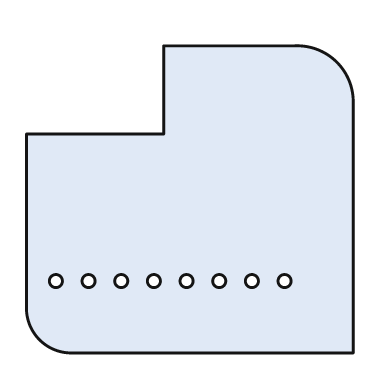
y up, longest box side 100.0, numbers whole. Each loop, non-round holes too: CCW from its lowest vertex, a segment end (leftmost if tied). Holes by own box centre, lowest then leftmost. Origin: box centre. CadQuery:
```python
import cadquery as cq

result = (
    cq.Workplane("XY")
    .moveTo(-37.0, -47.0)
    .lineTo(50.0, -47.0)
    .lineTo(50.0, 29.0)
    .threePointArc((45.0, 42.0), (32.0, 47.0))
    .lineTo(-8.0, 47.0)
    .lineTo(-8.0, 20.0)
    .lineTo(-50.0, 20.0)
    .lineTo(-50.0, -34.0)
    .threePointArc((-46.0, -43.0), (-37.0, -47.0))
    .close()
    .moveTo(-41.0, -25.0)
    .circle(2.0)
    .moveTo(-31.0, -25.0)
    .circle(2.0)
    .moveTo(-21.0, -25.0)
    .circle(2.0)
    .moveTo(-11.0, -25.0)
    .circle(2.0)
    .moveTo(-1.0, -25.0)
    .circle(2.0)
    .moveTo(9.0, -25.0)
    .circle(2.0)
    .moveTo(19.0, -25.0)
    .circle(2.0)
    .moveTo(29.0, -25.0)
    .circle(2.0)
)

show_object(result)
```